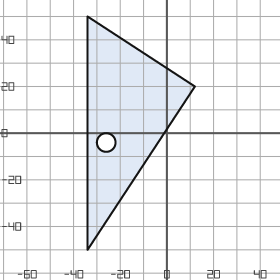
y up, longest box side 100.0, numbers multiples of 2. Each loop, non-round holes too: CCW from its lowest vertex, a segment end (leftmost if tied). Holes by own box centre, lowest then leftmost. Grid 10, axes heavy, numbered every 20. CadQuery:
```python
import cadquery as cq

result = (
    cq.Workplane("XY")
    .moveTo(-34.0, -50.0)
    .lineTo(12.0, 20.0)
    .lineTo(-34.0, 50.0)
    .close()
    .moveTo(-26.0, -4.0)
    .circle(4.0)
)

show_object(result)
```